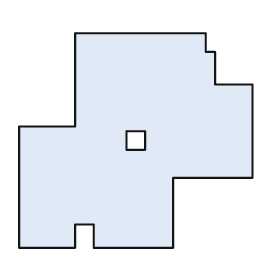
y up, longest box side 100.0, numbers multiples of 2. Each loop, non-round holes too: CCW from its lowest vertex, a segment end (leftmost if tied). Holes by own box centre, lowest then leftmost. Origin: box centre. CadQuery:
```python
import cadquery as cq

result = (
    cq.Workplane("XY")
    .moveTo(-50.0, -46.0)
    .lineTo(-26.0, -46.0)
    .lineTo(-26.0, -36.0)
    .lineTo(-18.0, -36.0)
    .lineTo(-18.0, -46.0)
    .lineTo(16.0, -46.0)
    .lineTo(16.0, -16.0)
    .lineTo(50.0, -16.0)
    .lineTo(50.0, 24.0)
    .lineTo(34.0, 24.0)
    .lineTo(34.0, 38.0)
    .lineTo(30.0, 38.0)
    .lineTo(30.0, 46.0)
    .lineTo(-26.0, 46.0)
    .lineTo(-26.0, 6.0)
    .lineTo(-50.0, 6.0)
    .close()
    .moveTo(-4.0, -4.0)
    .lineTo(4.0, -4.0)
    .lineTo(4.0, 4.0)
    .lineTo(-4.0, 4.0)
    .close()
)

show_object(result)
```